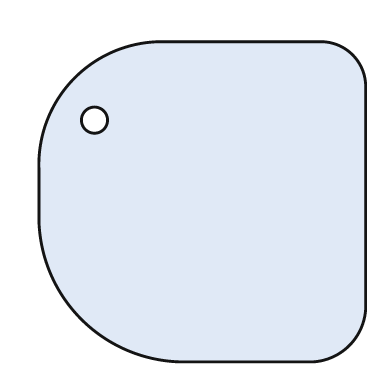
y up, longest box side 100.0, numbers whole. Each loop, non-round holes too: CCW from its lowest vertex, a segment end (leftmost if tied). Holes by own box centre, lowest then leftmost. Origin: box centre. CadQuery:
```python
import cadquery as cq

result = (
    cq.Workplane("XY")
    .moveTo(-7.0, -49.0)
    .lineTo(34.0, -49.0)
    .threePointArc((45.0, -44.0), (50.0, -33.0))
    .lineTo(50.0, 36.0)
    .threePointArc((46.0, 45.0), (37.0, 49.0))
    .lineTo(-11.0, 49.0)
    .threePointArc((-39.0, 38.0), (-50.0, 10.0))
    .lineTo(-50.0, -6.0)
    .threePointArc((-37.0, -36.0), (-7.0, -49.0))
    .close()
    .moveTo(-33.0, 25.0)
    .circle(4.0)
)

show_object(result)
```